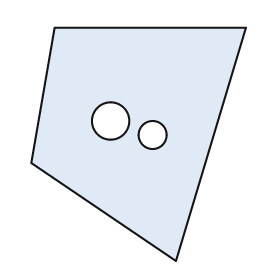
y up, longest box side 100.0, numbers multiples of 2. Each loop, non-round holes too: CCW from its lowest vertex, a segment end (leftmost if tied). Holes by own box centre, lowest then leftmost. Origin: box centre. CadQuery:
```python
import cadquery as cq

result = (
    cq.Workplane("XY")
    .moveTo(16.0, -50.0)
    .lineTo(46.0, 50.0)
    .lineTo(-36.0, 50.0)
    .lineTo(-46.0, -8.0)
    .close()
    .moveTo(6.0, 4.0)
    .circle(6.0)
    .moveTo(-12.0, 10.0)
    .circle(8.0)
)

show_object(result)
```